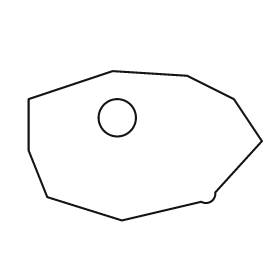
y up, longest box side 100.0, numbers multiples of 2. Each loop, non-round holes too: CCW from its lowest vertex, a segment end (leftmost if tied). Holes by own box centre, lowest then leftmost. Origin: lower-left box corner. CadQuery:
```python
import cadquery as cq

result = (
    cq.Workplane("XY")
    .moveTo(40.0, 0.0)
    .lineTo(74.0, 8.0)
    .threePointArc((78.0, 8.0), (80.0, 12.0))
    .lineTo(100.0, 34.0)
    .lineTo(88.0, 52.0)
    .lineTo(68.0, 62.0)
    .lineTo(36.0, 64.0)
    .lineTo(0.0, 52.0)
    .lineTo(0.0, 30.0)
    .lineTo(8.0, 10.0)
    .close()
    .moveTo(38.0, 44.0)
    .circle(8.0)
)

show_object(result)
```